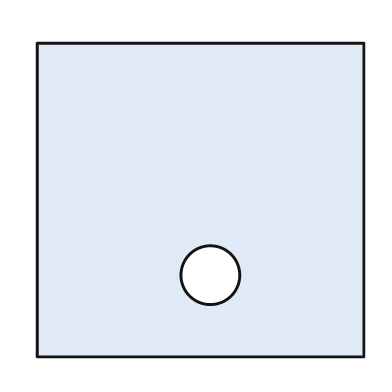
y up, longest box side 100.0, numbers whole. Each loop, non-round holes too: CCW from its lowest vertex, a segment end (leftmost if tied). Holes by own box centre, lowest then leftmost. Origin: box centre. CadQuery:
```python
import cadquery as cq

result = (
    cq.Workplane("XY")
    .moveTo(-50.0, -48.0)
    .lineTo(50.0, -48.0)
    .lineTo(50.0, 48.0)
    .lineTo(-50.0, 48.0)
    .close()
    .moveTo(3.0, -23.0)
    .circle(9.0)
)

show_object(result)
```